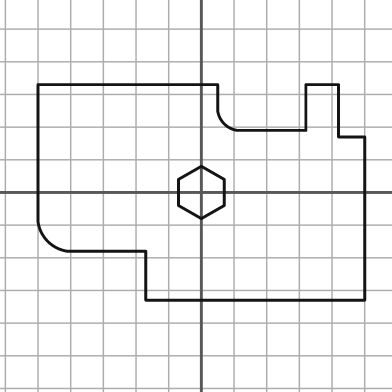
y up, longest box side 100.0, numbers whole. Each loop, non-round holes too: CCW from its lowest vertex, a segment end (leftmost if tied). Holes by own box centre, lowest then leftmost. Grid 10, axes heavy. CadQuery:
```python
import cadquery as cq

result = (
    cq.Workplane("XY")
    .moveTo(-17.0, -33.0)
    .lineTo(50.0, -33.0)
    .lineTo(50.0, 17.0)
    .lineTo(42.0, 17.0)
    .lineTo(42.0, 33.0)
    .lineTo(32.0, 33.0)
    .lineTo(32.0, 19.0)
    .lineTo(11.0, 19.0)
    .threePointArc((7.0, 21.0), (5.0, 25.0))
    .lineTo(5.0, 33.0)
    .lineTo(-50.0, 33.0)
    .lineTo(-50.0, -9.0)
    .threePointArc((-47.0, -15.0), (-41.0, -18.0))
    .lineTo(-17.0, -18.0)
    .close()
    .moveTo(0.0, -8.0)
    .lineTo(7.0, -4.0)
    .lineTo(7.0, 4.0)
    .lineTo(0.0, 8.0)
    .lineTo(-7.0, 4.0)
    .lineTo(-7.0, -4.0)
    .close()
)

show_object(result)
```